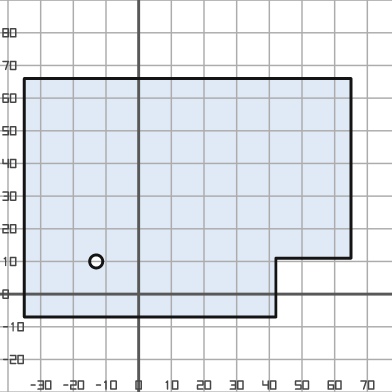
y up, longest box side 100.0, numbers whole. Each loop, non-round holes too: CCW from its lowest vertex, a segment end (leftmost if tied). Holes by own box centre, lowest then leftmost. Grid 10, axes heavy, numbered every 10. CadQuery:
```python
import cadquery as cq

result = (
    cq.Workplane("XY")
    .moveTo(-35.0, -7.0)
    .lineTo(42.0, -7.0)
    .lineTo(42.0, 11.0)
    .lineTo(65.0, 11.0)
    .lineTo(65.0, 66.0)
    .lineTo(-35.0, 66.0)
    .close()
    .moveTo(-13.0, 10.0)
    .circle(2.0)
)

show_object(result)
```